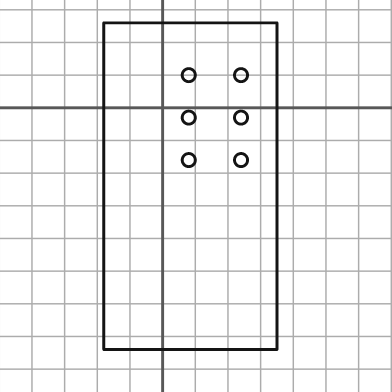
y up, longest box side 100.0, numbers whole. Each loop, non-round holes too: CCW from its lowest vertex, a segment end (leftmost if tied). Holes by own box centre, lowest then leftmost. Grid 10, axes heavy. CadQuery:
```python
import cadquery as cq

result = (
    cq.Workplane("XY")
    .moveTo(-18.0, -74.0)
    .lineTo(35.0, -74.0)
    .lineTo(35.0, 26.0)
    .lineTo(-18.0, 26.0)
    .close()
    .moveTo(8.0, -16.0)
    .circle(2.0)
    .moveTo(24.0, -16.0)
    .circle(2.0)
    .moveTo(8.0, -3.0)
    .circle(2.0)
    .moveTo(24.0, -3.0)
    .circle(2.0)
    .moveTo(8.0, 10.0)
    .circle(2.0)
    .moveTo(24.0, 10.0)
    .circle(2.0)
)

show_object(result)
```